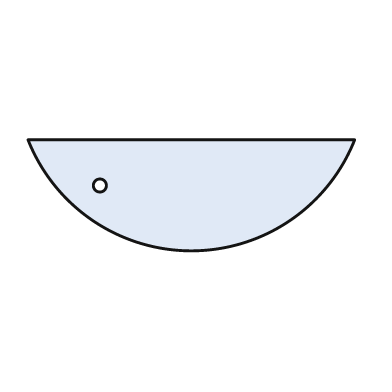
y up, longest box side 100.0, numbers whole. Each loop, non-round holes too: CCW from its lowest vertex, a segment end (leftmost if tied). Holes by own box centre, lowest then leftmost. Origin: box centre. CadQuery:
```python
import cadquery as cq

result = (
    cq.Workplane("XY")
    .moveTo(-50.0, 17.0)
    .threePointArc((0.0, -17.0), (50.0, 17.0))
    .close()
    .moveTo(-28.0, 3.0)
    .circle(2.0)
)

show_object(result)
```